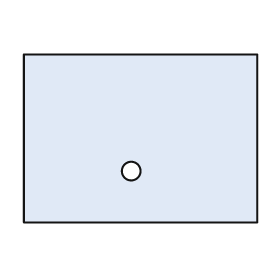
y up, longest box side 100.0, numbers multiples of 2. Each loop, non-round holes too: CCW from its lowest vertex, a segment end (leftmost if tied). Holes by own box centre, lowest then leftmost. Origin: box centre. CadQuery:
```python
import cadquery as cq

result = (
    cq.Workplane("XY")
    .moveTo(-50.0, -36.0)
    .lineTo(50.0, -36.0)
    .lineTo(50.0, 36.0)
    .lineTo(-50.0, 36.0)
    .close()
    .moveTo(-4.0, -14.0)
    .circle(4.0)
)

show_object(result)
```